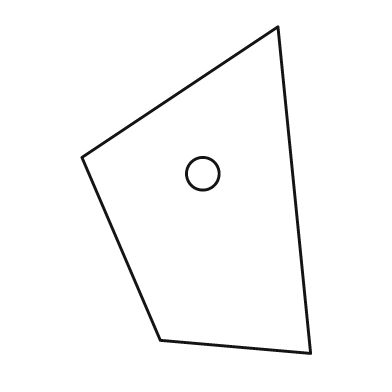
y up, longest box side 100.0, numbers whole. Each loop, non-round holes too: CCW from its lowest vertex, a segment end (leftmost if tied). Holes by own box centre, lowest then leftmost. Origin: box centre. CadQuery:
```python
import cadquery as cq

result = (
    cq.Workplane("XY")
    .moveTo(35.0, -50.0)
    .lineTo(25.0, 50.0)
    .lineTo(-35.0, 10.0)
    .lineTo(-11.0, -46.0)
    .close()
    .moveTo(2.0, 5.0)
    .circle(5.0)
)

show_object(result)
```